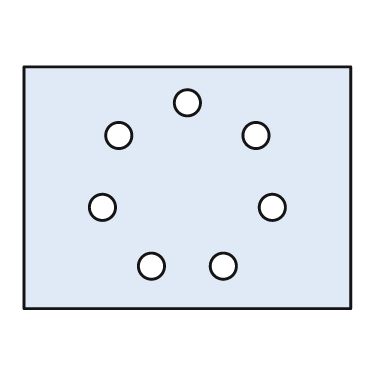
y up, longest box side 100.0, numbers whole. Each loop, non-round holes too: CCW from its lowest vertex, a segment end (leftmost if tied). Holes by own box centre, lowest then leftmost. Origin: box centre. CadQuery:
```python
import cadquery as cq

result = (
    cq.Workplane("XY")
    .moveTo(-50.0, -37.0)
    .lineTo(50.0, -37.0)
    .lineTo(50.0, 37.0)
    .lineTo(-50.0, 37.0)
    .close()
    .moveTo(-11.0, -24.0)
    .circle(4.0)
    .moveTo(11.0, -24.0)
    .circle(4.0)
    .moveTo(-26.0, -6.0)
    .circle(4.0)
    .moveTo(26.0, -6.0)
    .circle(4.0)
    .moveTo(-21.0, 16.0)
    .circle(4.0)
    .moveTo(21.0, 16.0)
    .circle(4.0)
    .moveTo(0.0, 26.0)
    .circle(4.0)
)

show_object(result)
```